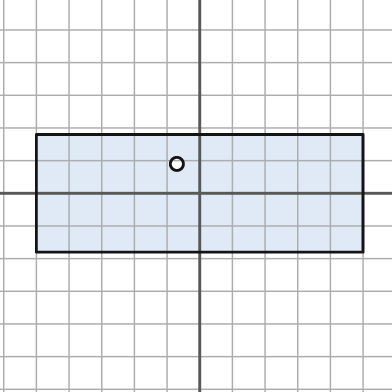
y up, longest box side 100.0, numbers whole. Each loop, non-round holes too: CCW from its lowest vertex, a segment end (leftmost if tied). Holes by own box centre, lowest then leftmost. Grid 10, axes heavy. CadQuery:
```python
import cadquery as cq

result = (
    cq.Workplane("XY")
    .moveTo(-50.0, -18.0)
    .lineTo(50.0, -18.0)
    .lineTo(50.0, 18.0)
    .lineTo(-50.0, 18.0)
    .close()
    .moveTo(-7.0, 9.0)
    .circle(2.0)
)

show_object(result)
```